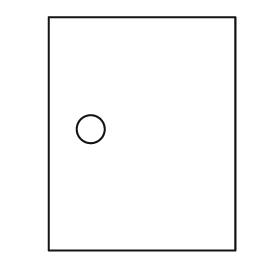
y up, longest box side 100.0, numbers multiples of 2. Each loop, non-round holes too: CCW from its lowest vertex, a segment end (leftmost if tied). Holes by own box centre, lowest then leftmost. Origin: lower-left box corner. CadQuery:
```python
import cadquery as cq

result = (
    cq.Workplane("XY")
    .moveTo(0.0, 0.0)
    .lineTo(80.0, 0.0)
    .lineTo(80.0, 100.0)
    .lineTo(0.0, 100.0)
    .close()
    .moveTo(18.0, 52.0)
    .circle(6.0)
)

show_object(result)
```